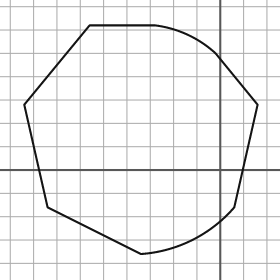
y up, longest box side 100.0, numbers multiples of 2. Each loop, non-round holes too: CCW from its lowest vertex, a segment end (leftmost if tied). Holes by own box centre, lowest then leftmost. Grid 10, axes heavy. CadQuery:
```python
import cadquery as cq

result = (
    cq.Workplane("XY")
    .moveTo(-34.0, -36.0)
    .threePointArc((-12.0, -30.0), (6.0, -16.0))
    .lineTo(16.0, 28.0)
    .lineTo(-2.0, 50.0)
    .threePointArc((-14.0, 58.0), (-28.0, 62.0))
    .lineTo(-56.0, 62.0)
    .lineTo(-84.0, 28.0)
    .lineTo(-74.0, -16.0)
    .close()
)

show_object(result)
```